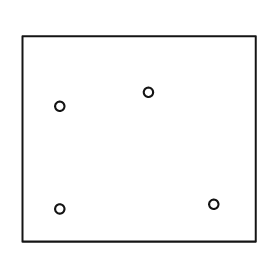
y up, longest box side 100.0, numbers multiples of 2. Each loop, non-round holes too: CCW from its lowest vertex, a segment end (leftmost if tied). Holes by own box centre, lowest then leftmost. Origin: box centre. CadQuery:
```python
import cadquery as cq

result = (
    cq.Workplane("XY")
    .moveTo(-50.0, -44.0)
    .lineTo(50.0, -44.0)
    .lineTo(50.0, 44.0)
    .lineTo(-50.0, 44.0)
    .close()
    .moveTo(-34.0, -30.0)
    .circle(2.0)
    .moveTo(32.0, -28.0)
    .circle(2.0)
    .moveTo(-34.0, 14.0)
    .circle(2.0)
    .moveTo(4.0, 20.0)
    .circle(2.0)
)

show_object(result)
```